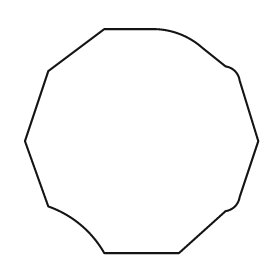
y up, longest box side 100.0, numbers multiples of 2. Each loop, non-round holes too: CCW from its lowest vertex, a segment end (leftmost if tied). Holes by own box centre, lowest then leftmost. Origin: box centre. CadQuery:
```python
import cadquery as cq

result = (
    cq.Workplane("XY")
    .moveTo(-16.0, -48.0)
    .lineTo(16.0, -48.0)
    .lineTo(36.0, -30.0)
    .threePointArc((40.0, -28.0), (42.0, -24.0))
    .lineTo(50.0, 0.0)
    .lineTo(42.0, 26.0)
    .threePointArc((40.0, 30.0), (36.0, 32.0))
    .lineTo(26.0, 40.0)
    .threePointArc((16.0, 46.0), (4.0, 48.0))
    .lineTo(-16.0, 48.0)
    .lineTo(-40.0, 30.0)
    .lineTo(-50.0, 0.0)
    .lineTo(-40.0, -28.0)
    .threePointArc((-26.0, -36.0), (-16.0, -48.0))
    .close()
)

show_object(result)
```